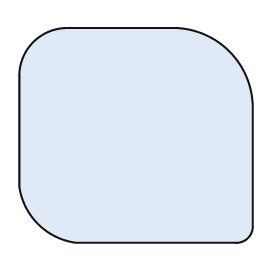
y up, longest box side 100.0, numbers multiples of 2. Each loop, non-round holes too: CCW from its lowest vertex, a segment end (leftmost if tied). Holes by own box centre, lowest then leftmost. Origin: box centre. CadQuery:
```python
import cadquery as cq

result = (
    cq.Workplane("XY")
    .moveTo(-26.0, -46.0)
    .lineTo(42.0, -46.0)
    .threePointArc((48.0, -44.0), (50.0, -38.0))
    .lineTo(50.0, 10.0)
    .threePointArc((40.0, 36.0), (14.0, 46.0))
    .lineTo(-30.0, 46.0)
    .threePointArc((-44.0, 40.0), (-50.0, 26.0))
    .lineTo(-50.0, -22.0)
    .threePointArc((-42.0, -38.0), (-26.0, -46.0))
    .close()
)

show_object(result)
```